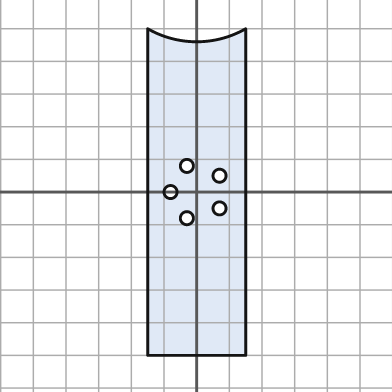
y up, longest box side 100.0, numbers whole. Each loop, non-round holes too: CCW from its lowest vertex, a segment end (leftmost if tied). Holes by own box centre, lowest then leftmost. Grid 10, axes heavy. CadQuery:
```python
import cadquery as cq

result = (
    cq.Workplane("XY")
    .moveTo(-15.0, -50.0)
    .lineTo(15.0, -50.0)
    .lineTo(15.0, 50.0)
    .threePointArc((0.0, 46.0), (-15.0, 50.0))
    .close()
    .moveTo(-3.0, -8.0)
    .circle(2.0)
    .moveTo(7.0, -5.0)
    .circle(2.0)
    .moveTo(-8.0, 0.0)
    .circle(2.0)
    .moveTo(7.0, 5.0)
    .circle(2.0)
    .moveTo(-3.0, 8.0)
    .circle(2.0)
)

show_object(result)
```